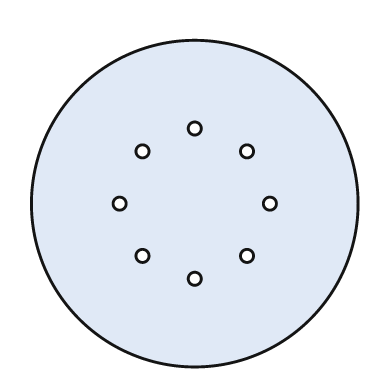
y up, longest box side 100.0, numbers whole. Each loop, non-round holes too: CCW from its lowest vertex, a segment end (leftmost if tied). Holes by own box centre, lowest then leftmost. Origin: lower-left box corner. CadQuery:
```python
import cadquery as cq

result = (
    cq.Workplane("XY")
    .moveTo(50.0, 50.0)
    .circle(50.0)
    .moveTo(50.0, 27.0)
    .circle(2.0)
    .moveTo(34.0, 34.0)
    .circle(2.0)
    .moveTo(66.0, 34.0)
    .circle(2.0)
    .moveTo(27.0, 50.0)
    .circle(2.0)
    .moveTo(73.0, 50.0)
    .circle(2.0)
    .moveTo(34.0, 66.0)
    .circle(2.0)
    .moveTo(66.0, 66.0)
    .circle(2.0)
    .moveTo(50.0, 73.0)
    .circle(2.0)
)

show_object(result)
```